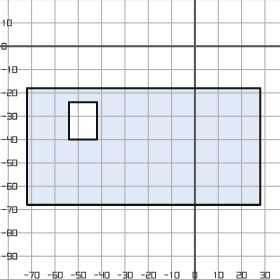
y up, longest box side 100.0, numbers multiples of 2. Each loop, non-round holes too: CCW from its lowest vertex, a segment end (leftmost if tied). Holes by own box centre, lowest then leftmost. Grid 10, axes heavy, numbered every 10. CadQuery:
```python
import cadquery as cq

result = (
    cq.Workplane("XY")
    .moveTo(-72.0, -68.0)
    .lineTo(28.0, -68.0)
    .lineTo(28.0, -18.0)
    .lineTo(-72.0, -18.0)
    .close()
    .moveTo(-54.0, -40.0)
    .lineTo(-42.0, -40.0)
    .lineTo(-42.0, -24.0)
    .lineTo(-54.0, -24.0)
    .close()
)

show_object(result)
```